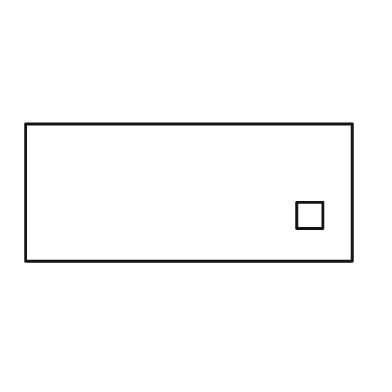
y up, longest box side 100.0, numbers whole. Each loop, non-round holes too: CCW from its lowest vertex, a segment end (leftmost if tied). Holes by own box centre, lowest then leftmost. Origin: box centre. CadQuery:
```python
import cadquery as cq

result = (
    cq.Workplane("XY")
    .moveTo(-50.0, -21.0)
    .lineTo(50.0, -21.0)
    .lineTo(50.0, 21.0)
    .lineTo(-50.0, 21.0)
    .close()
    .moveTo(33.0, -11.0)
    .lineTo(41.0, -11.0)
    .lineTo(41.0, -3.0)
    .lineTo(33.0, -3.0)
    .close()
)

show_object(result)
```